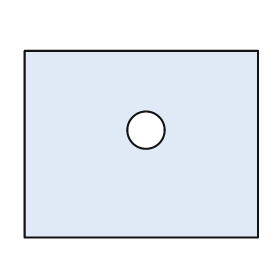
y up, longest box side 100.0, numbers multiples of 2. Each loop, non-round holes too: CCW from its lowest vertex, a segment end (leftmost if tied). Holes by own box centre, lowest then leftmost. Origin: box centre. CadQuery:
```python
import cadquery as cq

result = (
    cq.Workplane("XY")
    .moveTo(-50.0, -40.0)
    .lineTo(50.0, -40.0)
    .lineTo(50.0, 40.0)
    .lineTo(-50.0, 40.0)
    .close()
    .moveTo(2.0, 6.0)
    .circle(8.0)
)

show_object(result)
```